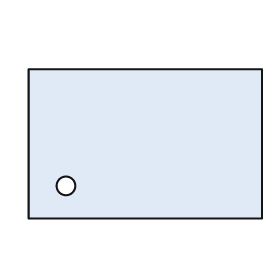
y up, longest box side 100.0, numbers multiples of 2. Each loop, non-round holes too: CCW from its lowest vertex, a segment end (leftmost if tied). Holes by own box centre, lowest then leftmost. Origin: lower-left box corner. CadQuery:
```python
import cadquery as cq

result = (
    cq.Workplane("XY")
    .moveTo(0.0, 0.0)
    .lineTo(100.0, 0.0)
    .lineTo(100.0, 64.0)
    .lineTo(0.0, 64.0)
    .close()
    .moveTo(16.0, 14.0)
    .circle(4.0)
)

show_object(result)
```